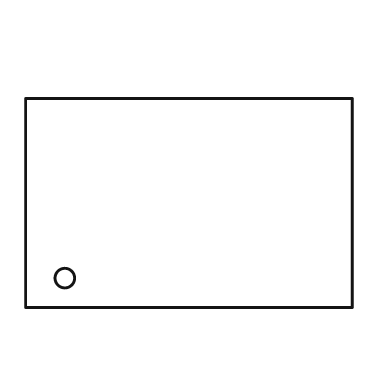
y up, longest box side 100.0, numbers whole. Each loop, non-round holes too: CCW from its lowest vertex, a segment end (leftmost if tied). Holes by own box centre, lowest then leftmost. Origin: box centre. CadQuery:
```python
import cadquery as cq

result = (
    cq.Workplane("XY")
    .moveTo(-50.0, -32.0)
    .lineTo(50.0, -32.0)
    .lineTo(50.0, 32.0)
    .lineTo(-50.0, 32.0)
    .close()
    .moveTo(-38.0, -23.0)
    .circle(3.0)
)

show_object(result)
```